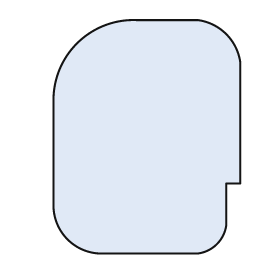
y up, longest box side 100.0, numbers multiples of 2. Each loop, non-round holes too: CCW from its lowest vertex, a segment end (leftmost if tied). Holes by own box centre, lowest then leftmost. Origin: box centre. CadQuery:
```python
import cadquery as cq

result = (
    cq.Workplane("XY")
    .moveTo(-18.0, -50.0)
    .lineTo(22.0, -50.0)
    .threePointArc((30.0, -46.0), (34.0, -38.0))
    .lineTo(34.0, -20.0)
    .lineTo(40.0, -20.0)
    .lineTo(40.0, 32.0)
    .threePointArc((34.0, 44.0), (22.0, 50.0))
    .lineTo(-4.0, 50.0)
    .threePointArc((-30.0, 40.0), (-40.0, 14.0))
    .lineTo(-40.0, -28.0)
    .threePointArc((-34.0, -44.0), (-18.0, -50.0))
    .close()
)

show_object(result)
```